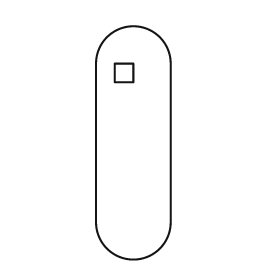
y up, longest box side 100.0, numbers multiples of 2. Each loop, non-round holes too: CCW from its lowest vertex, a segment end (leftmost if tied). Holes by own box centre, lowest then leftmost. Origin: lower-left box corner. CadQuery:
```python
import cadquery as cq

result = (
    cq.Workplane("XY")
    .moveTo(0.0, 16.0)
    .threePointArc((16.0, 0.0), (32.0, 16.0))
    .lineTo(32.0, 84.0)
    .threePointArc((16.0, 100.0), (0.0, 84.0))
    .close()
    .moveTo(8.0, 76.0)
    .lineTo(16.0, 76.0)
    .lineTo(16.0, 84.0)
    .lineTo(8.0, 84.0)
    .close()
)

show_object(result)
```